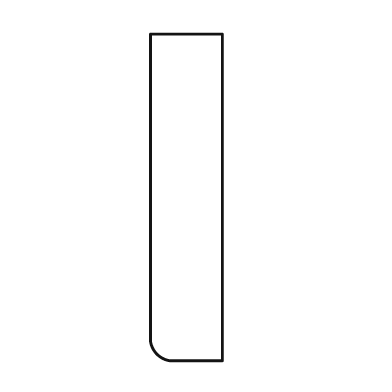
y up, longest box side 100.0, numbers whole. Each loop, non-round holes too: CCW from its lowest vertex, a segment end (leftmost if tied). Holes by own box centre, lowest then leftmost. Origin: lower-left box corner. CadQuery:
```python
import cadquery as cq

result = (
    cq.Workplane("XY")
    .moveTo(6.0, 0.0)
    .lineTo(22.0, 0.0)
    .lineTo(22.0, 100.0)
    .lineTo(0.0, 100.0)
    .lineTo(0.0, 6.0)
    .threePointArc((2.0, 2.0), (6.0, 0.0))
    .close()
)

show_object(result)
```